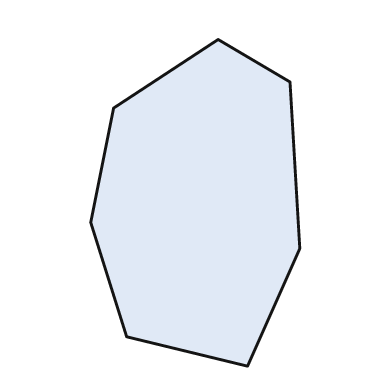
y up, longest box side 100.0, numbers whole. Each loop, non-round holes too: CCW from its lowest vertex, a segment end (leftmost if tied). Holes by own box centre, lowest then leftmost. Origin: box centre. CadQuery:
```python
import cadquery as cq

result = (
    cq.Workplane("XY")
    .moveTo(16.0, -50.0)
    .lineTo(32.0, -14.0)
    .lineTo(29.0, 37.0)
    .lineTo(7.0, 50.0)
    .lineTo(-25.0, 29.0)
    .lineTo(-32.0, -6.0)
    .lineTo(-21.0, -41.0)
    .close()
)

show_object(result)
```